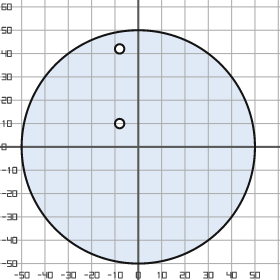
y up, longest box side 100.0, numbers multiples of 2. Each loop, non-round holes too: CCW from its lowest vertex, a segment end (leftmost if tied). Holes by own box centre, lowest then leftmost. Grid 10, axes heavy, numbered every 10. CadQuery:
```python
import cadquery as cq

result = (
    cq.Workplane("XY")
    .moveTo(0.0, 0.0)
    .circle(50.0)
    .moveTo(-8.0, 10.0)
    .circle(2.0)
    .moveTo(-8.0, 42.0)
    .circle(2.0)
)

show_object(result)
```